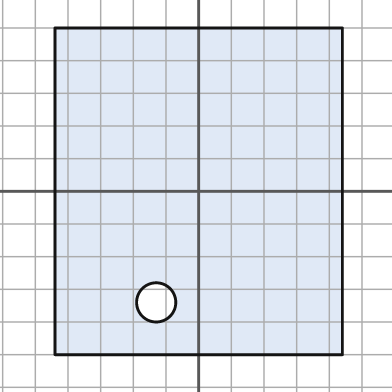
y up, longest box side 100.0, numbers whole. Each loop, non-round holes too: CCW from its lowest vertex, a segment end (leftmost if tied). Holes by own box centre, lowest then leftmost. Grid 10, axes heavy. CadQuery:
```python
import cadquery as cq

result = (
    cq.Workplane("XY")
    .moveTo(-44.0, -50.0)
    .lineTo(44.0, -50.0)
    .lineTo(44.0, 50.0)
    .lineTo(-44.0, 50.0)
    .close()
    .moveTo(-13.0, -34.0)
    .circle(6.0)
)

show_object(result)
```